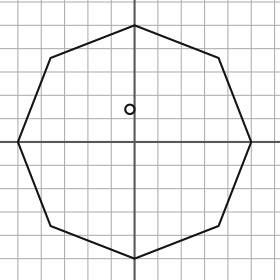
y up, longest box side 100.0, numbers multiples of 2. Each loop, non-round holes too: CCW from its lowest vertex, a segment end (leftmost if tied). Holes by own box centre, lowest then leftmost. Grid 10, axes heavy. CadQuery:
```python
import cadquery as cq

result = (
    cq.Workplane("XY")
    .moveTo(0.0, -50.0)
    .lineTo(36.0, -36.0)
    .lineTo(50.0, 0.0)
    .lineTo(36.0, 36.0)
    .lineTo(0.0, 50.0)
    .lineTo(-36.0, 36.0)
    .lineTo(-50.0, 0.0)
    .lineTo(-36.0, -36.0)
    .close()
    .moveTo(-2.0, 14.0)
    .circle(2.0)
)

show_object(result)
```